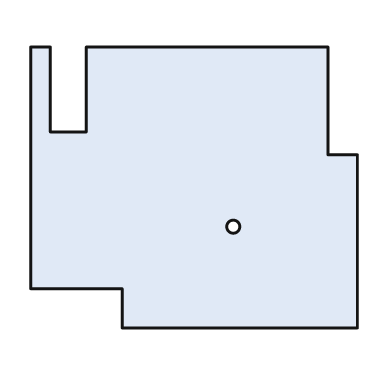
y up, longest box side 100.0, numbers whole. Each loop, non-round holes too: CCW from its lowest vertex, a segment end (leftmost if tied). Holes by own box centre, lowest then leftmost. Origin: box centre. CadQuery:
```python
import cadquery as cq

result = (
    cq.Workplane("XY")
    .moveTo(-22.0, -43.0)
    .lineTo(50.0, -43.0)
    .lineTo(50.0, 10.0)
    .lineTo(41.0, 10.0)
    .lineTo(41.0, 43.0)
    .lineTo(-33.0, 43.0)
    .lineTo(-33.0, 17.0)
    .lineTo(-44.0, 17.0)
    .lineTo(-44.0, 43.0)
    .lineTo(-50.0, 43.0)
    .lineTo(-50.0, -31.0)
    .lineTo(-22.0, -31.0)
    .close()
    .moveTo(12.0, -12.0)
    .circle(2.0)
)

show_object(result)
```